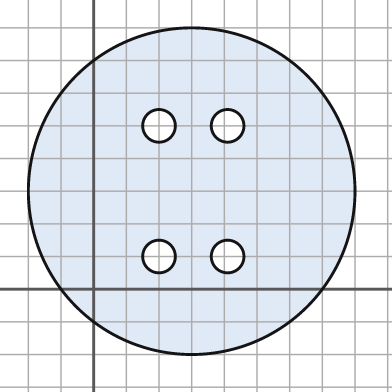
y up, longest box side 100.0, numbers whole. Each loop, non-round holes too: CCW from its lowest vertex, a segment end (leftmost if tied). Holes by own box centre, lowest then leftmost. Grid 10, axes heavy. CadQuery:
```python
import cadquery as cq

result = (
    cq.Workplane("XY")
    .moveTo(30.0, 30.0)
    .circle(50.0)
    .moveTo(20.0, 10.0)
    .circle(5.0)
    .moveTo(41.0, 10.0)
    .circle(5.0)
    .moveTo(20.0, 50.0)
    .circle(5.0)
    .moveTo(41.0, 50.0)
    .circle(5.0)
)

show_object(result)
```